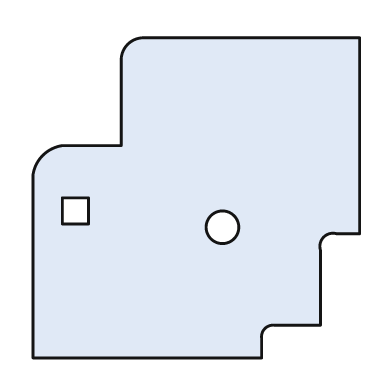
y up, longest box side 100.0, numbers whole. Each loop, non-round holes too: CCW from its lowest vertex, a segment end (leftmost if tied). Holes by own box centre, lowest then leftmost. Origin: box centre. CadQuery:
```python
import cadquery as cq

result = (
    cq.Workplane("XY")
    .moveTo(-50.0, -49.0)
    .lineTo(20.0, -49.0)
    .lineTo(20.0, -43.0)
    .threePointArc((21.0, -40.0), (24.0, -39.0))
    .lineTo(38.0, -39.0)
    .lineTo(38.0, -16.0)
    .threePointArc((39.0, -12.0), (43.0, -11.0))
    .lineTo(50.0, -11.0)
    .lineTo(50.0, 49.0)
    .lineTo(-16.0, 49.0)
    .threePointArc((-21.0, 47.0), (-23.0, 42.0))
    .lineTo(-23.0, 16.0)
    .lineTo(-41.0, 16.0)
    .threePointArc((-47.0, 13.0), (-50.0, 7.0))
    .close()
    .moveTo(8.0, -9.0)
    .circle(5.0)
    .moveTo(-41.0, -8.0)
    .lineTo(-33.0, -8.0)
    .lineTo(-33.0, 0.0)
    .lineTo(-41.0, 0.0)
    .close()
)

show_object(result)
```